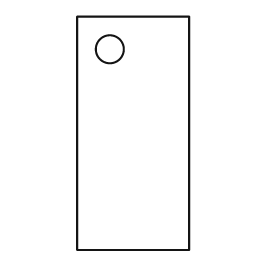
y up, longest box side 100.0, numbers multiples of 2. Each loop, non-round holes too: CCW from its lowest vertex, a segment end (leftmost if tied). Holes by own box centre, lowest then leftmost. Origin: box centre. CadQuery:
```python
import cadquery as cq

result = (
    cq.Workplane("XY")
    .moveTo(-24.0, -50.0)
    .lineTo(24.0, -50.0)
    .lineTo(24.0, 50.0)
    .lineTo(-24.0, 50.0)
    .close()
    .moveTo(-10.0, 36.0)
    .circle(6.0)
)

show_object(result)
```